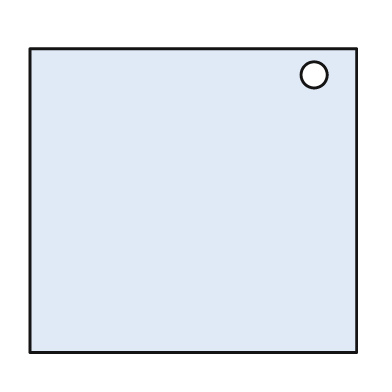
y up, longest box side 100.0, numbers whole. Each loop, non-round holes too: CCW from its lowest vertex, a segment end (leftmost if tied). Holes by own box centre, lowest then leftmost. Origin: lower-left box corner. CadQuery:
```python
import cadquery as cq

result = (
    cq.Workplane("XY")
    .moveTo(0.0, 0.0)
    .lineTo(100.0, 0.0)
    .lineTo(100.0, 93.0)
    .lineTo(0.0, 93.0)
    .close()
    .moveTo(87.0, 85.0)
    .circle(4.0)
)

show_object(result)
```